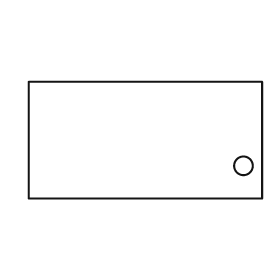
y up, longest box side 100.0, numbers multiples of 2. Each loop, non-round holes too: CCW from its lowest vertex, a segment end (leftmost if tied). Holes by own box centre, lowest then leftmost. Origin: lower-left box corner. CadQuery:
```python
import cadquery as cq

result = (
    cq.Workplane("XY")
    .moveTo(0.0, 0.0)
    .lineTo(100.0, 0.0)
    .lineTo(100.0, 50.0)
    .lineTo(0.0, 50.0)
    .close()
    .moveTo(92.0, 14.0)
    .circle(4.0)
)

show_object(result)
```